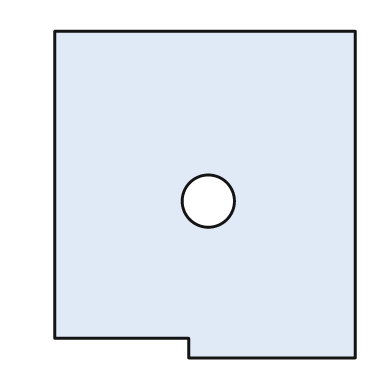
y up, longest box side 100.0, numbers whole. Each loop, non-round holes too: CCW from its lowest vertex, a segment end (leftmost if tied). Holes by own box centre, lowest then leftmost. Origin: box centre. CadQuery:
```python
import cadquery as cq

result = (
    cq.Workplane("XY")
    .moveTo(-5.0, -50.0)
    .lineTo(46.0, -50.0)
    .lineTo(46.0, 50.0)
    .lineTo(-46.0, 50.0)
    .lineTo(-46.0, -44.0)
    .lineTo(-5.0, -44.0)
    .close()
    .moveTo(1.0, -2.0)
    .circle(8.0)
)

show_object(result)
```